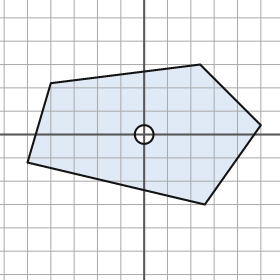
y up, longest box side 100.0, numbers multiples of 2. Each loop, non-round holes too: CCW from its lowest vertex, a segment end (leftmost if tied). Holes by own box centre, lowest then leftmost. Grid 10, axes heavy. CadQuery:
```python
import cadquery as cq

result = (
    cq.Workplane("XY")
    .moveTo(26.0, -30.0)
    .lineTo(50.0, 4.0)
    .lineTo(24.0, 30.0)
    .lineTo(-40.0, 22.0)
    .lineTo(-50.0, -12.0)
    .close()
    .moveTo(0.0, 0.0)
    .circle(4.0)
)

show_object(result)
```